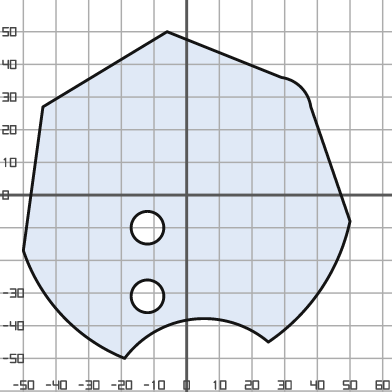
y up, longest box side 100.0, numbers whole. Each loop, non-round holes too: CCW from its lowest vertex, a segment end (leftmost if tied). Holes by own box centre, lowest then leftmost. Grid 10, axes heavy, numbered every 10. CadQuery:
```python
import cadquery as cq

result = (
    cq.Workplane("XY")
    .moveTo(-19.0, -50.0)
    .threePointArc((2.0, -38.0), (25.0, -45.0))
    .threePointArc((41.0, -29.0), (50.0, -8.0))
    .lineTo(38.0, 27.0)
    .threePointArc((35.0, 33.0), (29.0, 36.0))
    .lineTo(-6.0, 50.0)
    .lineTo(-44.0, 27.0)
    .lineTo(-50.0, -17.0)
    .threePointArc((-38.0, -37.0), (-19.0, -50.0))
    .close()
    .moveTo(-12.0, -31.0)
    .circle(5.0)
    .moveTo(-12.0, -10.0)
    .circle(5.0)
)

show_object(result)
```